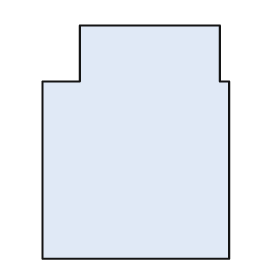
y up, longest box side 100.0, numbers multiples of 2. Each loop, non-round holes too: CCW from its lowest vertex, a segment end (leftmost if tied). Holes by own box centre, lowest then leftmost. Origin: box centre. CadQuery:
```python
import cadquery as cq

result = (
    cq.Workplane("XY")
    .moveTo(-40.0, -50.0)
    .lineTo(40.0, -50.0)
    .lineTo(40.0, 26.0)
    .lineTo(36.0, 26.0)
    .lineTo(36.0, 50.0)
    .lineTo(-24.0, 50.0)
    .lineTo(-24.0, 26.0)
    .lineTo(-40.0, 26.0)
    .close()
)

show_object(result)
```